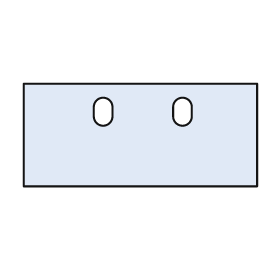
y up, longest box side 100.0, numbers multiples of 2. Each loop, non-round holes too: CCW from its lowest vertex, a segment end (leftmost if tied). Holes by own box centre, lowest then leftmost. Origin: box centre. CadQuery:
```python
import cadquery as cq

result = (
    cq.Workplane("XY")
    .moveTo(-50.0, -22.0)
    .lineTo(50.0, -22.0)
    .lineTo(50.0, 22.0)
    .lineTo(-50.0, 22.0)
    .close()
    .moveTo(-20.0, 8.0)
    .threePointArc((-16.0, 4.0), (-12.0, 8.0))
    .lineTo(-12.0, 12.0)
    .threePointArc((-16.0, 16.0), (-20.0, 12.0))
    .close()
    .moveTo(14.0, 8.0)
    .threePointArc((18.0, 4.0), (22.0, 8.0))
    .lineTo(22.0, 12.0)
    .threePointArc((18.0, 16.0), (14.0, 12.0))
    .close()
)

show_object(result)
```